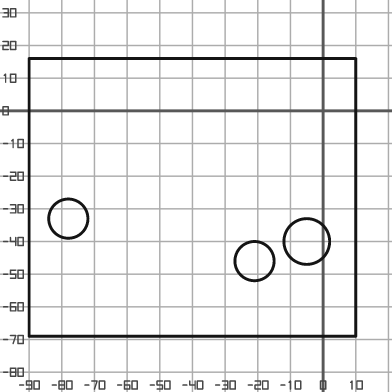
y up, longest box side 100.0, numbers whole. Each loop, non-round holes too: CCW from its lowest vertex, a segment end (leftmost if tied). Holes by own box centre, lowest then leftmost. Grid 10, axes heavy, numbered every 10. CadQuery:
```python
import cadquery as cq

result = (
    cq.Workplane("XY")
    .moveTo(-90.0, -69.0)
    .lineTo(10.0, -69.0)
    .lineTo(10.0, 16.0)
    .lineTo(-90.0, 16.0)
    .close()
    .moveTo(-21.0, -46.0)
    .circle(6.0)
    .moveTo(-5.0, -40.0)
    .circle(7.0)
    .moveTo(-78.0, -33.0)
    .circle(6.0)
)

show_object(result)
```